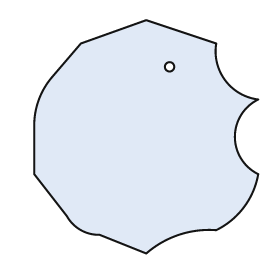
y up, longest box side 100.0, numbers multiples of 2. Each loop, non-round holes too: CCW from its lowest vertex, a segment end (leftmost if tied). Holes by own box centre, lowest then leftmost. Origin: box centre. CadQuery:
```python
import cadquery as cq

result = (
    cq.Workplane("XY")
    .moveTo(0.0, -50.0)
    .threePointArc((14.0, -42.0), (30.0, -40.0))
    .threePointArc((42.0, -30.0), (48.0, -16.0))
    .threePointArc((38.0, 0.0), (48.0, 16.0))
    .threePointArc((34.0, 24.0), (30.0, 40.0))
    .lineTo(0.0, 50.0)
    .lineTo(-28.0, 40.0)
    .lineTo(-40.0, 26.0)
    .threePointArc((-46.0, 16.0), (-48.0, 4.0))
    .lineTo(-48.0, -16.0)
    .lineTo(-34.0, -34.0)
    .threePointArc((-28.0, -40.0), (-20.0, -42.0))
    .close()
    .moveTo(10.0, 30.0)
    .circle(2.0)
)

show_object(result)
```